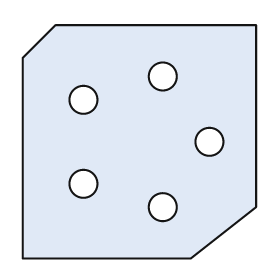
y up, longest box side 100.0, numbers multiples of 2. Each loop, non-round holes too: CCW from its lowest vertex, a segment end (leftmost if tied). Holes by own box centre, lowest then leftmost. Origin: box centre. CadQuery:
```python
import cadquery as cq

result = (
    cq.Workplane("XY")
    .moveTo(-50.0, -50.0)
    .lineTo(22.0, -50.0)
    .lineTo(50.0, -28.0)
    .lineTo(50.0, 50.0)
    .lineTo(-36.0, 50.0)
    .lineTo(-50.0, 36.0)
    .close()
    .moveTo(10.0, -28.0)
    .circle(6.0)
    .moveTo(-24.0, -18.0)
    .circle(6.0)
    .moveTo(30.0, 0.0)
    .circle(6.0)
    .moveTo(-24.0, 18.0)
    .circle(6.0)
    .moveTo(10.0, 28.0)
    .circle(6.0)
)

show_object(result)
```